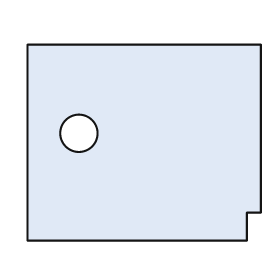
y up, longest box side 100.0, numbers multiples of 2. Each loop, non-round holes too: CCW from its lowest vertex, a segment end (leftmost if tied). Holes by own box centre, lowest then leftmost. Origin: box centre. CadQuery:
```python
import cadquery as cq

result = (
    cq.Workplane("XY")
    .moveTo(-50.0, -42.0)
    .lineTo(44.0, -42.0)
    .lineTo(44.0, -30.0)
    .lineTo(50.0, -30.0)
    .lineTo(50.0, 42.0)
    .lineTo(-50.0, 42.0)
    .close()
    .moveTo(-28.0, 4.0)
    .circle(8.0)
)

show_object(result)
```